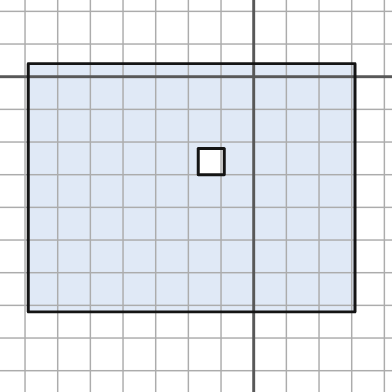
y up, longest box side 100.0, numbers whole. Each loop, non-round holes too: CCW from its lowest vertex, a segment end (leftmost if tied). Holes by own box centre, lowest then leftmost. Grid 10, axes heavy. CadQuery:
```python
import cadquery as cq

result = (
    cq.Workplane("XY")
    .moveTo(-69.0, -72.0)
    .lineTo(31.0, -72.0)
    .lineTo(31.0, 4.0)
    .lineTo(-69.0, 4.0)
    .close()
    .moveTo(-17.0, -30.0)
    .lineTo(-9.0, -30.0)
    .lineTo(-9.0, -22.0)
    .lineTo(-17.0, -22.0)
    .close()
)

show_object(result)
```